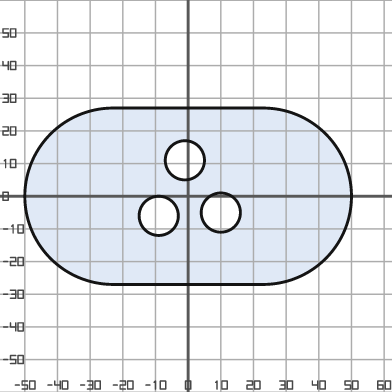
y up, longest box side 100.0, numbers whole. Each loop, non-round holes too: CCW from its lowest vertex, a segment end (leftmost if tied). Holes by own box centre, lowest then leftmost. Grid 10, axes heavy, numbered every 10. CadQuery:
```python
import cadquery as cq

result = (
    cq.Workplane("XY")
    .moveTo(-23.0, -27.0)
    .lineTo(23.0, -27.0)
    .threePointArc((50.0, 0.0), (23.0, 27.0))
    .lineTo(-23.0, 27.0)
    .threePointArc((-50.0, 0.0), (-23.0, -27.0))
    .close()
    .moveTo(-9.0, -6.0)
    .circle(6.0)
    .moveTo(10.0, -5.0)
    .circle(6.0)
    .moveTo(-1.0, 11.0)
    .circle(6.0)
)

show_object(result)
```